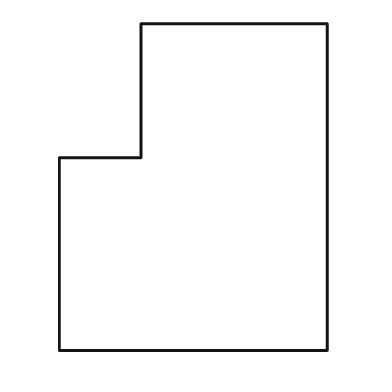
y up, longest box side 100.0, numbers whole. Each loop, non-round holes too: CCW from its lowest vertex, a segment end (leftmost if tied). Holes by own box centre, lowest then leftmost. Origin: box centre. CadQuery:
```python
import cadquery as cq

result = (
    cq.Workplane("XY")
    .moveTo(-41.0, -50.0)
    .lineTo(41.0, -50.0)
    .lineTo(41.0, 50.0)
    .lineTo(-16.0, 50.0)
    .lineTo(-16.0, 9.0)
    .lineTo(-41.0, 9.0)
    .close()
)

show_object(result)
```